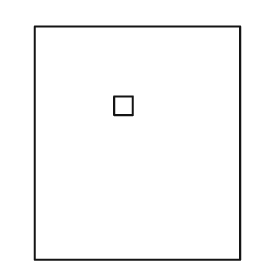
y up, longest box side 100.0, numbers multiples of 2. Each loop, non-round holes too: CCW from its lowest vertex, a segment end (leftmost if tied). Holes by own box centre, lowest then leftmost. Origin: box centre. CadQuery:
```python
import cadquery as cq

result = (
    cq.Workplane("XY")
    .moveTo(-44.0, -50.0)
    .lineTo(44.0, -50.0)
    .lineTo(44.0, 50.0)
    .lineTo(-44.0, 50.0)
    .close()
    .moveTo(-10.0, 12.0)
    .lineTo(-2.0, 12.0)
    .lineTo(-2.0, 20.0)
    .lineTo(-10.0, 20.0)
    .close()
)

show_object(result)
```